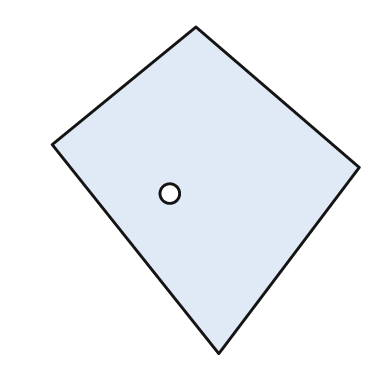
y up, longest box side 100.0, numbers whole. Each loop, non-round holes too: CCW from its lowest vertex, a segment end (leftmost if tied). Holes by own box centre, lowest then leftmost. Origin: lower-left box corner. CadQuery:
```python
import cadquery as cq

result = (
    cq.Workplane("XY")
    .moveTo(51.0, 0.0)
    .lineTo(94.0, 57.0)
    .lineTo(44.0, 100.0)
    .lineTo(0.0, 64.0)
    .close()
    .moveTo(36.0, 49.0)
    .circle(3.0)
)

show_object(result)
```